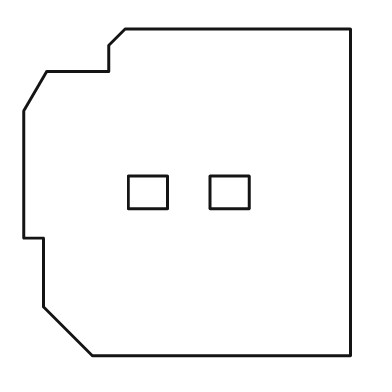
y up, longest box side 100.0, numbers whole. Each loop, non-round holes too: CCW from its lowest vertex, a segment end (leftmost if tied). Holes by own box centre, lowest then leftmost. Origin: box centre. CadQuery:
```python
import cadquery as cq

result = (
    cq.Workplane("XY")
    .moveTo(-29.0, -50.0)
    .lineTo(50.0, -50.0)
    .lineTo(50.0, 50.0)
    .lineTo(-19.0, 50.0)
    .lineTo(-24.0, 45.0)
    .lineTo(-24.0, 37.0)
    .lineTo(-43.0, 37.0)
    .lineTo(-50.0, 25.0)
    .lineTo(-50.0, -14.0)
    .lineTo(-44.0, -14.0)
    .lineTo(-44.0, -35.0)
    .close()
    .moveTo(-18.0, -5.0)
    .lineTo(-6.0, -5.0)
    .lineTo(-6.0, 5.0)
    .lineTo(-18.0, 5.0)
    .close()
    .moveTo(7.0, -5.0)
    .lineTo(19.0, -5.0)
    .lineTo(19.0, 5.0)
    .lineTo(7.0, 5.0)
    .close()
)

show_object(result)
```